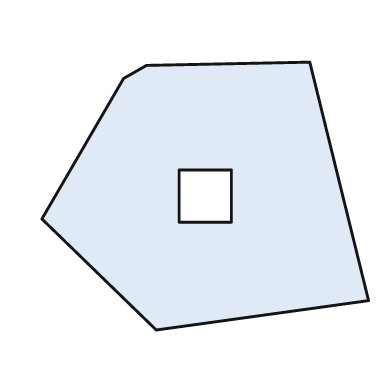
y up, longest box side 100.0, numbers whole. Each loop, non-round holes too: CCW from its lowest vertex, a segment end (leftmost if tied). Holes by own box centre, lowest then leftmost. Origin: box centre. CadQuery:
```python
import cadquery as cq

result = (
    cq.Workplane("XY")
    .moveTo(-15.0, -41.0)
    .lineTo(50.0, -32.0)
    .lineTo(32.0, 41.0)
    .lineTo(-18.0, 40.0)
    .lineTo(-25.0, 36.0)
    .lineTo(-50.0, -7.0)
    .close()
    .moveTo(-8.0, -8.0)
    .lineTo(8.0, -8.0)
    .lineTo(8.0, 8.0)
    .lineTo(-8.0, 8.0)
    .close()
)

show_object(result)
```